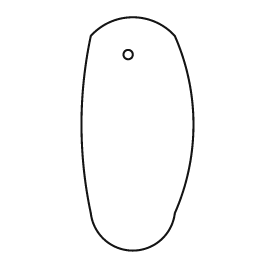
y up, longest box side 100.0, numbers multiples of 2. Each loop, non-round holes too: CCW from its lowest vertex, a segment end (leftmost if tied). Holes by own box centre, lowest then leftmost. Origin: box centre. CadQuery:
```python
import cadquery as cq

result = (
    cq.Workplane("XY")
    .moveTo(-20.0, -34.0)
    .threePointArc((-2.0, -50.0), (16.0, -34.0))
    .threePointArc((24.0, 4.0), (16.0, 42.0))
    .threePointArc((-2.0, 50.0), (-20.0, 42.0))
    .threePointArc((-24.0, 4.0), (-20.0, -34.0))
    .close()
    .moveTo(-4.0, 34.0)
    .circle(2.0)
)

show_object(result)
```